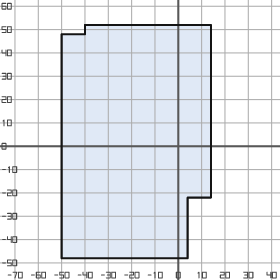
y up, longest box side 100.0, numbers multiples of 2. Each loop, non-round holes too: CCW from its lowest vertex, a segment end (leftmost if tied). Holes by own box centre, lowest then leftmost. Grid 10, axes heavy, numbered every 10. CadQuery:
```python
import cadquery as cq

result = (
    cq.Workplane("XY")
    .moveTo(-50.0, -48.0)
    .lineTo(4.0, -48.0)
    .lineTo(4.0, -22.0)
    .lineTo(14.0, -22.0)
    .lineTo(14.0, 52.0)
    .lineTo(-40.0, 52.0)
    .lineTo(-40.0, 48.0)
    .lineTo(-50.0, 48.0)
    .close()
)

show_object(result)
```